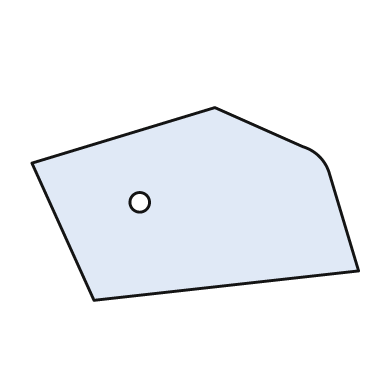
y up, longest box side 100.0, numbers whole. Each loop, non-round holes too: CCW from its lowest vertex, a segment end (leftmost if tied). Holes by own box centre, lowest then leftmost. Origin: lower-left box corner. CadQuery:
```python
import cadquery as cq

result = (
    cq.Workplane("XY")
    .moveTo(19.0, 0.0)
    .lineTo(100.0, 9.0)
    .lineTo(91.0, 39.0)
    .threePointArc((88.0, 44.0), (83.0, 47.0))
    .lineTo(56.0, 59.0)
    .lineTo(0.0, 42.0)
    .close()
    .moveTo(33.0, 30.0)
    .circle(3.0)
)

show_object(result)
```